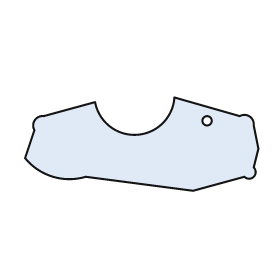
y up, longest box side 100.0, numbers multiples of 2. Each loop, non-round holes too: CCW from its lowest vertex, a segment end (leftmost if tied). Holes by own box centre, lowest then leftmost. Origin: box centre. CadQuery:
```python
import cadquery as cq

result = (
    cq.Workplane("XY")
    .moveTo(22.0, -20.0)
    .lineTo(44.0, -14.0)
    .threePointArc((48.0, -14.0), (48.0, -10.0))
    .lineTo(50.0, -2.0)
    .lineTo(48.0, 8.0)
    .threePointArc((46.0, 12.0), (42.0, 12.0))
    .lineTo(14.0, 20.0)
    .threePointArc((-2.0, 4.0), (-20.0, 18.0))
    .lineTo(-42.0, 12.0)
    .threePointArc((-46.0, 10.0), (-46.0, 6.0))
    .lineTo(-50.0, -6.0)
    .threePointArc((-38.0, -14.0), (-24.0, -14.0))
    .close()
    .moveTo(28.0, 10.0)
    .circle(2.0)
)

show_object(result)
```